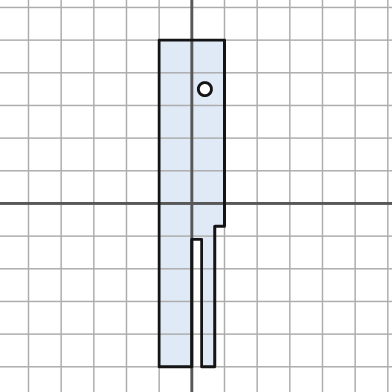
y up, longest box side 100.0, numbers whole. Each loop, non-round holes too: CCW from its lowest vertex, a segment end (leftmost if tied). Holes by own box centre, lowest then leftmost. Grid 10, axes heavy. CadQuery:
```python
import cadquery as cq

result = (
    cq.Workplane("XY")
    .moveTo(-10.0, -50.0)
    .lineTo(0.0, -50.0)
    .lineTo(0.0, -11.0)
    .lineTo(3.0, -11.0)
    .lineTo(3.0, -50.0)
    .lineTo(7.0, -50.0)
    .lineTo(7.0, -7.0)
    .lineTo(10.0, -7.0)
    .lineTo(10.0, 50.0)
    .lineTo(-10.0, 50.0)
    .close()
    .moveTo(4.0, 35.0)
    .circle(2.0)
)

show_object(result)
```